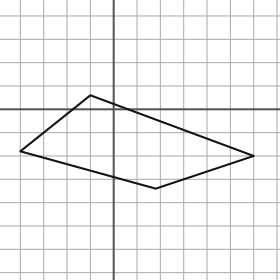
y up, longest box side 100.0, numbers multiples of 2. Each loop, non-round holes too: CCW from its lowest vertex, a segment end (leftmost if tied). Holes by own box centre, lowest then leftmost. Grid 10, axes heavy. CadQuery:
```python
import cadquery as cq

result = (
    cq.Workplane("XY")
    .moveTo(18.0, -34.0)
    .lineTo(60.0, -20.0)
    .lineTo(-10.0, 6.0)
    .lineTo(-40.0, -18.0)
    .close()
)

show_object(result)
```